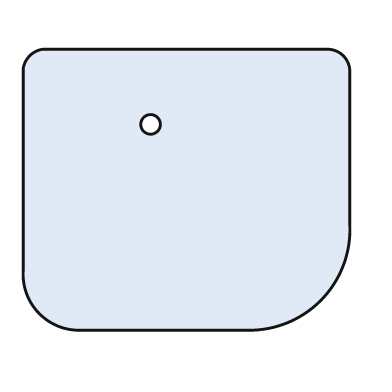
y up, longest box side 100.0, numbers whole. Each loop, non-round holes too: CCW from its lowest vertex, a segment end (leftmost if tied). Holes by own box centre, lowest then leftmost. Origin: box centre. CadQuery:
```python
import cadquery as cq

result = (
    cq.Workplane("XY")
    .moveTo(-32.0, -43.0)
    .lineTo(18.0, -43.0)
    .threePointArc((41.0, -34.0), (50.0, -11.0))
    .lineTo(50.0, 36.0)
    .threePointArc((48.0, 41.0), (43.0, 43.0))
    .lineTo(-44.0, 43.0)
    .threePointArc((-48.0, 41.0), (-50.0, 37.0))
    .lineTo(-50.0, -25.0)
    .threePointArc((-45.0, -38.0), (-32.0, -43.0))
    .close()
    .moveTo(-11.0, 20.0)
    .circle(3.0)
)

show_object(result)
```